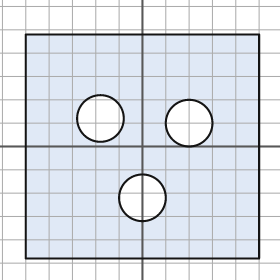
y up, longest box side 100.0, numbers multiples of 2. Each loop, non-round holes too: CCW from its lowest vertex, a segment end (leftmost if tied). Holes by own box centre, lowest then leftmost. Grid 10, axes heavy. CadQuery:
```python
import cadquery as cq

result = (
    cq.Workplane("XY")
    .moveTo(-50.0, -48.0)
    .lineTo(50.0, -48.0)
    .lineTo(50.0, 48.0)
    .lineTo(-50.0, 48.0)
    .close()
    .moveTo(0.0, -22.0)
    .circle(10.0)
    .moveTo(20.0, 10.0)
    .circle(10.0)
    .moveTo(-18.0, 12.0)
    .circle(10.0)
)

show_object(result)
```